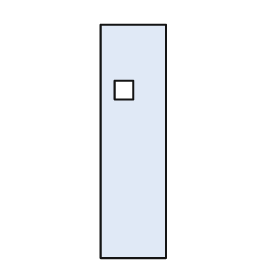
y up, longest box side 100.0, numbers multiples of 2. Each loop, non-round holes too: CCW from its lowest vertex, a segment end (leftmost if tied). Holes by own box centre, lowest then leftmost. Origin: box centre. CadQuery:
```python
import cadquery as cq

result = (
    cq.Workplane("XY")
    .moveTo(-14.0, -50.0)
    .lineTo(14.0, -50.0)
    .lineTo(14.0, 50.0)
    .lineTo(-14.0, 50.0)
    .close()
    .moveTo(-8.0, 18.0)
    .lineTo(0.0, 18.0)
    .lineTo(0.0, 26.0)
    .lineTo(-8.0, 26.0)
    .close()
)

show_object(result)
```